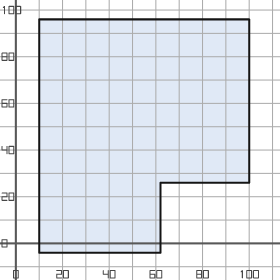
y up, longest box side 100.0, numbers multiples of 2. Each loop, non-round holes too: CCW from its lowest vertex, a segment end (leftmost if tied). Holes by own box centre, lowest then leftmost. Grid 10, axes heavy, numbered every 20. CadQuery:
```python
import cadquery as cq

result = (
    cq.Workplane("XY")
    .moveTo(10.0, -4.0)
    .lineTo(62.0, -4.0)
    .lineTo(62.0, 26.0)
    .lineTo(100.0, 26.0)
    .lineTo(100.0, 96.0)
    .lineTo(10.0, 96.0)
    .close()
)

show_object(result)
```